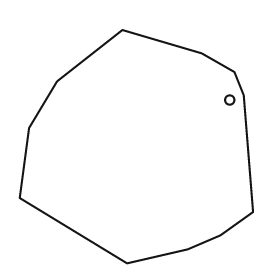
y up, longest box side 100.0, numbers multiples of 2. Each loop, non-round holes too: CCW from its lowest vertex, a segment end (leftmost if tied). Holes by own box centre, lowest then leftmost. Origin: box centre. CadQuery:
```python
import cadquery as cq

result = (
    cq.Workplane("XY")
    .moveTo(-4.0, -50.0)
    .lineTo(22.0, -44.0)
    .lineTo(36.0, -38.0)
    .lineTo(50.0, -28.0)
    .lineTo(46.0, 22.0)
    .lineTo(42.0, 32.0)
    .lineTo(28.0, 40.0)
    .lineTo(-6.0, 50.0)
    .lineTo(-34.0, 28.0)
    .lineTo(-46.0, 8.0)
    .lineTo(-50.0, -22.0)
    .close()
    .moveTo(40.0, 20.0)
    .circle(2.0)
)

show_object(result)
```